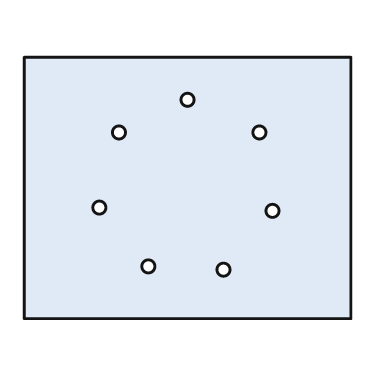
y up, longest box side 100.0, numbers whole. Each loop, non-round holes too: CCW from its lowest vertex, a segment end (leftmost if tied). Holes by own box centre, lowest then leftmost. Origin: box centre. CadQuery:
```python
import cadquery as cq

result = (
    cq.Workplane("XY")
    .moveTo(-50.0, -40.0)
    .lineTo(50.0, -40.0)
    .lineTo(50.0, 40.0)
    .lineTo(-50.0, 40.0)
    .close()
    .moveTo(11.0, -25.0)
    .circle(2.0)
    .moveTo(-12.0, -24.0)
    .circle(2.0)
    .moveTo(26.0, -7.0)
    .circle(2.0)
    .moveTo(-27.0, -6.0)
    .circle(2.0)
    .moveTo(-21.0, 17.0)
    .circle(2.0)
    .moveTo(22.0, 17.0)
    .circle(2.0)
    .moveTo(0.0, 27.0)
    .circle(2.0)
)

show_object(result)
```